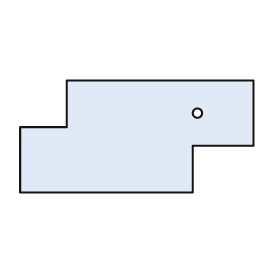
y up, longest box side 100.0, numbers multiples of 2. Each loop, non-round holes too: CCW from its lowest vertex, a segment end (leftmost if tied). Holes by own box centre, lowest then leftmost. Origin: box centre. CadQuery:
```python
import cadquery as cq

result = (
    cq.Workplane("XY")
    .moveTo(-50.0, -24.0)
    .lineTo(24.0, -24.0)
    .lineTo(24.0, -4.0)
    .lineTo(50.0, -4.0)
    .lineTo(50.0, 24.0)
    .lineTo(-30.0, 24.0)
    .lineTo(-30.0, 4.0)
    .lineTo(-50.0, 4.0)
    .close()
    .moveTo(26.0, 10.0)
    .circle(2.0)
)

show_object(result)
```